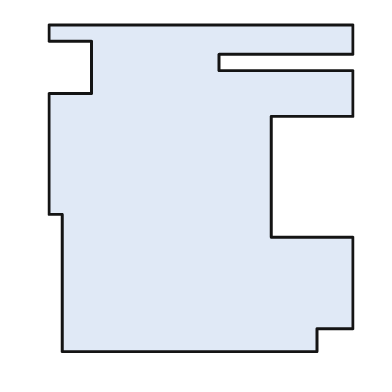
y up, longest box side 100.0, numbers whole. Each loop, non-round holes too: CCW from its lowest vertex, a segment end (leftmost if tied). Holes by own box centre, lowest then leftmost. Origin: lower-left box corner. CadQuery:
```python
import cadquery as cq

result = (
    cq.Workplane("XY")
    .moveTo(4.0, 0.0)
    .lineTo(82.0, 0.0)
    .lineTo(82.0, 7.0)
    .lineTo(93.0, 7.0)
    .lineTo(93.0, 35.0)
    .lineTo(68.0, 35.0)
    .lineTo(68.0, 72.0)
    .lineTo(93.0, 72.0)
    .lineTo(93.0, 86.0)
    .lineTo(52.0, 86.0)
    .lineTo(52.0, 91.0)
    .lineTo(93.0, 91.0)
    .lineTo(93.0, 100.0)
    .lineTo(0.0, 100.0)
    .lineTo(0.0, 95.0)
    .lineTo(13.0, 95.0)
    .lineTo(13.0, 79.0)
    .lineTo(0.0, 79.0)
    .lineTo(0.0, 42.0)
    .lineTo(4.0, 42.0)
    .close()
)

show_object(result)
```